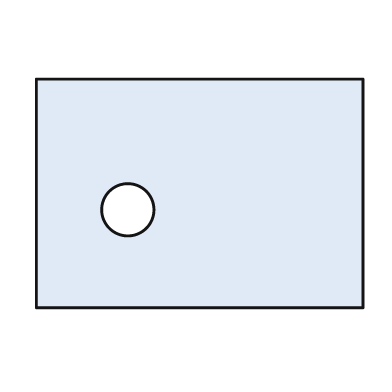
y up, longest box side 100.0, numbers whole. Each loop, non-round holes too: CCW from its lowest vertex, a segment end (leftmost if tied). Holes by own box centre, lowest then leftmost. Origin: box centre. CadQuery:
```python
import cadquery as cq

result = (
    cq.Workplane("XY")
    .moveTo(-50.0, -35.0)
    .lineTo(50.0, -35.0)
    .lineTo(50.0, 35.0)
    .lineTo(-50.0, 35.0)
    .close()
    .moveTo(-22.0, -5.0)
    .circle(8.0)
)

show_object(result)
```